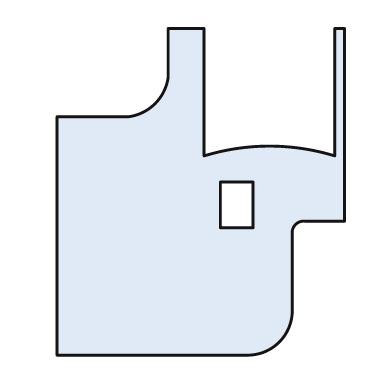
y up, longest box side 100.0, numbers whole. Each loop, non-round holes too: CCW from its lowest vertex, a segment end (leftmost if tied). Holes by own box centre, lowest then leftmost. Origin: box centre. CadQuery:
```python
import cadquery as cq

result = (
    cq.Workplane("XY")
    .moveTo(-44.0, -50.0)
    .lineTo(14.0, -50.0)
    .threePointArc((24.0, -46.0), (28.0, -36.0))
    .lineTo(28.0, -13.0)
    .threePointArc((29.0, -10.0), (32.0, -9.0))
    .lineTo(44.0, -9.0)
    .lineTo(44.0, 50.0)
    .lineTo(41.0, 50.0)
    .lineTo(41.0, 11.0)
    .threePointArc((21.0, 14.0), (1.0, 11.0))
    .lineTo(1.0, 50.0)
    .lineTo(-10.0, 50.0)
    .lineTo(-10.0, 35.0)
    .threePointArc((-14.0, 27.0), (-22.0, 23.0))
    .lineTo(-44.0, 23.0)
    .close()
    .moveTo(6.0, -11.0)
    .lineTo(16.0, -11.0)
    .lineTo(16.0, 3.0)
    .lineTo(6.0, 3.0)
    .close()
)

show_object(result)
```